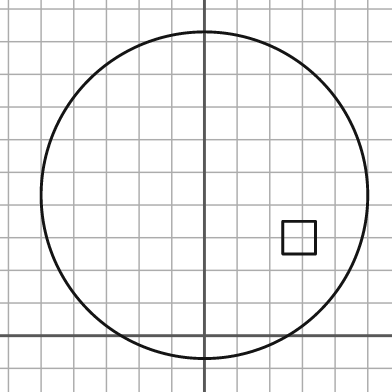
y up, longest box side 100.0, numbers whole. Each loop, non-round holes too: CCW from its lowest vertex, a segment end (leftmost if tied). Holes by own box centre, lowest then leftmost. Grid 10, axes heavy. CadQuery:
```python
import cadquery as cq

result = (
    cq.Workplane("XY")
    .moveTo(0.0, 43.0)
    .circle(50.0)
    .moveTo(24.0, 25.0)
    .lineTo(34.0, 25.0)
    .lineTo(34.0, 35.0)
    .lineTo(24.0, 35.0)
    .close()
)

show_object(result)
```